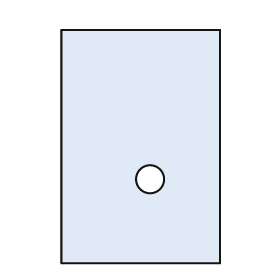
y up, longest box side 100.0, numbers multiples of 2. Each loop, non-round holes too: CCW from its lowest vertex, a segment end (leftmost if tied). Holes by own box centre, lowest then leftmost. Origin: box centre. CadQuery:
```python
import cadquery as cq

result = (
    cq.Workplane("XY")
    .moveTo(-34.0, -50.0)
    .lineTo(34.0, -50.0)
    .lineTo(34.0, 50.0)
    .lineTo(-34.0, 50.0)
    .close()
    .moveTo(4.0, -14.0)
    .circle(6.0)
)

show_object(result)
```